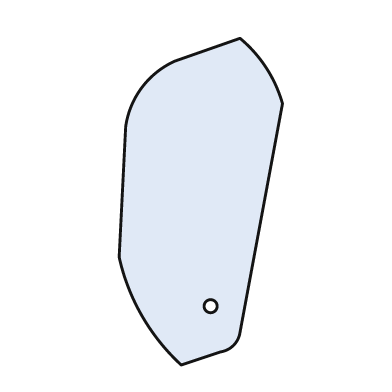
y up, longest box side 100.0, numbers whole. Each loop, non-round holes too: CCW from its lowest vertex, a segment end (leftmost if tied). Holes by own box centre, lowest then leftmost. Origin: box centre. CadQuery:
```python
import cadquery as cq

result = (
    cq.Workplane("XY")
    .moveTo(-6.0, -50.0)
    .lineTo(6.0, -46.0)
    .threePointArc((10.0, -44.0), (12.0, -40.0))
    .lineTo(25.0, 30.0)
    .threePointArc((20.0, 41.0), (12.0, 50.0))
    .lineTo(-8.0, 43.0)
    .threePointArc((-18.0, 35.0), (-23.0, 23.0))
    .lineTo(-25.0, -17.0)
    .threePointArc((-18.0, -35.0), (-6.0, -50.0))
    .close()
    .moveTo(3.0, -32.0)
    .circle(2.0)
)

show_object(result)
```